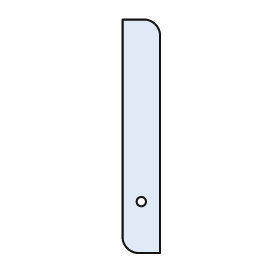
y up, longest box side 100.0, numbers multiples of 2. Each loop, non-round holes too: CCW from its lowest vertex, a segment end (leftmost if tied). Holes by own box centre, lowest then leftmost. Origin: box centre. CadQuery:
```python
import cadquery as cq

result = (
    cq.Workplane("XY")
    .moveTo(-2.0, -50.0)
    .lineTo(8.0, -50.0)
    .lineTo(8.0, 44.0)
    .threePointArc((6.0, 48.0), (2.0, 50.0))
    .lineTo(-8.0, 50.0)
    .lineTo(-8.0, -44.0)
    .threePointArc((-6.0, -48.0), (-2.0, -50.0))
    .close()
    .moveTo(0.0, -28.0)
    .circle(2.0)
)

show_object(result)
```